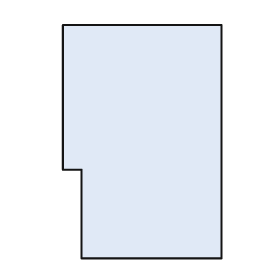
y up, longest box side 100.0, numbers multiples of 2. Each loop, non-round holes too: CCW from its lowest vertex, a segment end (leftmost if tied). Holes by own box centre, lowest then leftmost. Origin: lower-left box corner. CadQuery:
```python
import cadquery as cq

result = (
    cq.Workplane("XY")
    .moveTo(8.0, 0.0)
    .lineTo(68.0, 0.0)
    .lineTo(68.0, 100.0)
    .lineTo(0.0, 100.0)
    .lineTo(0.0, 38.0)
    .lineTo(8.0, 38.0)
    .close()
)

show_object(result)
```